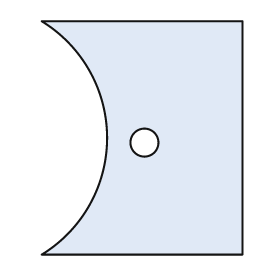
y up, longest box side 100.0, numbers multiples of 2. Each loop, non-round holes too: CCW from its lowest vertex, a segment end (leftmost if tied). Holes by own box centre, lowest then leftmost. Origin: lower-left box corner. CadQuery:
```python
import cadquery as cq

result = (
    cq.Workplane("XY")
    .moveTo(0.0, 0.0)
    .lineTo(86.0, 0.0)
    .lineTo(86.0, 100.0)
    .lineTo(0.0, 100.0)
    .threePointArc((28.0, 50.0), (0.0, 0.0))
    .close()
    .moveTo(44.0, 48.0)
    .circle(6.0)
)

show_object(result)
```